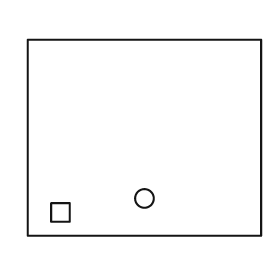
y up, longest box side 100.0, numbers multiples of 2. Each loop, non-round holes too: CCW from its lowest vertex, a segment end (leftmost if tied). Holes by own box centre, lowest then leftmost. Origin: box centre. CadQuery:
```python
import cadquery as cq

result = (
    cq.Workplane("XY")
    .moveTo(-50.0, -42.0)
    .lineTo(50.0, -42.0)
    .lineTo(50.0, 42.0)
    .lineTo(-50.0, 42.0)
    .close()
    .moveTo(-40.0, -36.0)
    .lineTo(-32.0, -36.0)
    .lineTo(-32.0, -28.0)
    .lineTo(-40.0, -28.0)
    .close()
    .moveTo(0.0, -26.0)
    .circle(4.0)
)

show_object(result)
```